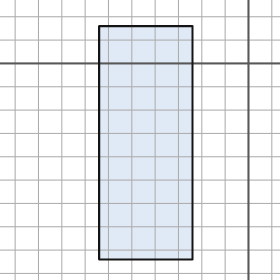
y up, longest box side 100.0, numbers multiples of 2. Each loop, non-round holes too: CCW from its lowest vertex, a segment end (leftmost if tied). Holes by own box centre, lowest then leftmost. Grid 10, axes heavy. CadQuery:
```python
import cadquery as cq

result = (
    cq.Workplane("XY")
    .moveTo(-64.0, -84.0)
    .lineTo(-24.0, -84.0)
    .lineTo(-24.0, 16.0)
    .lineTo(-64.0, 16.0)
    .close()
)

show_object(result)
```